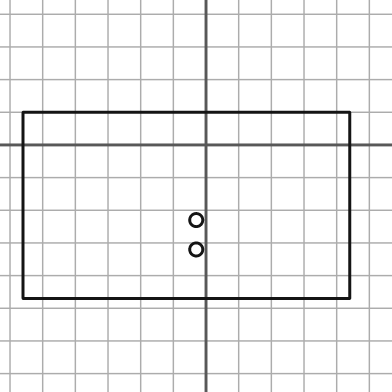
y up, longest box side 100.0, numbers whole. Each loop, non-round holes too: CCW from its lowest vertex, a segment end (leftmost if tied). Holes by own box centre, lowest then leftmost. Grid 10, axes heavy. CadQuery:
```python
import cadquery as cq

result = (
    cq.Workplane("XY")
    .moveTo(-56.0, -47.0)
    .lineTo(44.0, -47.0)
    .lineTo(44.0, 10.0)
    .lineTo(-56.0, 10.0)
    .close()
    .moveTo(-3.0, -32.0)
    .circle(2.0)
    .moveTo(-3.0, -23.0)
    .circle(2.0)
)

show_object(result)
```